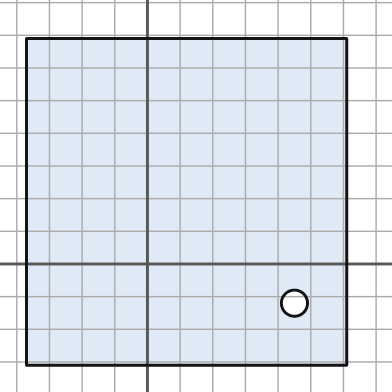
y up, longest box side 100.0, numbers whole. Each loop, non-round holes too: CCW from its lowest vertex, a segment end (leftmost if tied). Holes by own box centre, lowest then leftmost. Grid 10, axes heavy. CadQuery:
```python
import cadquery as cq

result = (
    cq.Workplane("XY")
    .moveTo(-37.0, -31.0)
    .lineTo(61.0, -31.0)
    .lineTo(61.0, 69.0)
    .lineTo(-37.0, 69.0)
    .close()
    .moveTo(45.0, -12.0)
    .circle(4.0)
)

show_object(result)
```